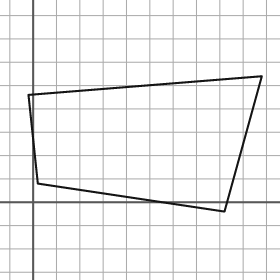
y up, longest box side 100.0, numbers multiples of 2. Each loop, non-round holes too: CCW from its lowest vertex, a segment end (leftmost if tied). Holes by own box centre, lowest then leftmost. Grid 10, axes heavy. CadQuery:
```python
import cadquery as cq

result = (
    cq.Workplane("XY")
    .moveTo(82.0, -4.0)
    .lineTo(98.0, 54.0)
    .lineTo(-2.0, 46.0)
    .lineTo(2.0, 8.0)
    .close()
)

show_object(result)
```